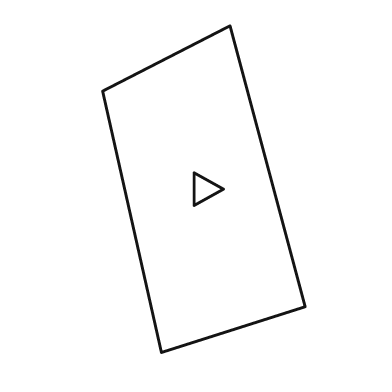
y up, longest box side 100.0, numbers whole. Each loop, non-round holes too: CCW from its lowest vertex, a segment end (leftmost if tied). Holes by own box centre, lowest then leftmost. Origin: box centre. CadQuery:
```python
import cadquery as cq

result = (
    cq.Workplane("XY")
    .moveTo(-13.0, -50.0)
    .lineTo(31.0, -36.0)
    .lineTo(8.0, 50.0)
    .lineTo(-31.0, 30.0)
    .close()
    .moveTo(-3.0, -5.0)
    .lineTo(6.0, 0.0)
    .lineTo(-3.0, 5.0)
    .close()
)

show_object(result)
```